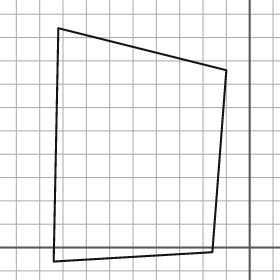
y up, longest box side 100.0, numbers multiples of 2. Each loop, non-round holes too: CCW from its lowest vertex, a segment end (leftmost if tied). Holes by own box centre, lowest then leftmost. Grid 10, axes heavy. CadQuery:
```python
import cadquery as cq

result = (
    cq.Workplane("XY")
    .moveTo(-84.0, -6.0)
    .lineTo(-16.0, -2.0)
    .lineTo(-10.0, 76.0)
    .lineTo(-82.0, 94.0)
    .close()
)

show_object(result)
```